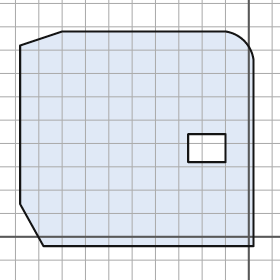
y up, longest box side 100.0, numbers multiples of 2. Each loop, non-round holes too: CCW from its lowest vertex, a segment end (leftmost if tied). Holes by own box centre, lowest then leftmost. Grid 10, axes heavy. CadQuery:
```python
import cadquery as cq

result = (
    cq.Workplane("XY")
    .moveTo(-88.0, -4.0)
    .lineTo(2.0, -4.0)
    .lineTo(2.0, 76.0)
    .threePointArc((-2.0, 84.0), (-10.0, 88.0))
    .lineTo(-80.0, 88.0)
    .lineTo(-98.0, 82.0)
    .lineTo(-98.0, 14.0)
    .close()
    .moveTo(-26.0, 32.0)
    .lineTo(-10.0, 32.0)
    .lineTo(-10.0, 44.0)
    .lineTo(-26.0, 44.0)
    .close()
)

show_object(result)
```